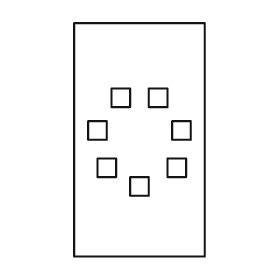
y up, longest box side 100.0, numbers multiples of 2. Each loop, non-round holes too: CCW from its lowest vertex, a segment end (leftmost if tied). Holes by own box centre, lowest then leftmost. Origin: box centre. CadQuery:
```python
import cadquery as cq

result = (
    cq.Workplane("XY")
    .moveTo(-28.0, -50.0)
    .lineTo(28.0, -50.0)
    .lineTo(28.0, 50.0)
    .lineTo(-28.0, 50.0)
    .close()
    .moveTo(-4.0, -24.0)
    .lineTo(4.0, -24.0)
    .lineTo(4.0, -16.0)
    .lineTo(-4.0, -16.0)
    .close()
    .moveTo(-18.0, -16.0)
    .lineTo(-10.0, -16.0)
    .lineTo(-10.0, -8.0)
    .lineTo(-18.0, -8.0)
    .close()
    .moveTo(12.0, -16.0)
    .lineTo(20.0, -16.0)
    .lineTo(20.0, -8.0)
    .lineTo(12.0, -8.0)
    .close()
    .moveTo(-22.0, 0.0)
    .lineTo(-14.0, 0.0)
    .lineTo(-14.0, 8.0)
    .lineTo(-22.0, 8.0)
    .close()
    .moveTo(14.0, 0.0)
    .lineTo(22.0, 0.0)
    .lineTo(22.0, 8.0)
    .lineTo(14.0, 8.0)
    .close()
    .moveTo(-12.0, 14.0)
    .lineTo(-4.0, 14.0)
    .lineTo(-4.0, 22.0)
    .lineTo(-12.0, 22.0)
    .close()
    .moveTo(4.0, 14.0)
    .lineTo(12.0, 14.0)
    .lineTo(12.0, 22.0)
    .lineTo(4.0, 22.0)
    .close()
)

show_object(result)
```